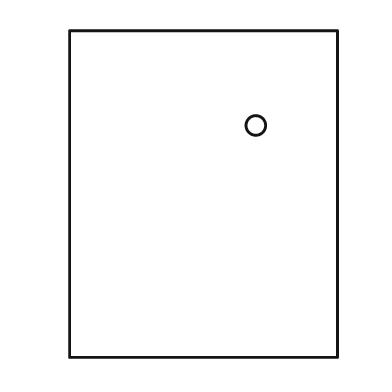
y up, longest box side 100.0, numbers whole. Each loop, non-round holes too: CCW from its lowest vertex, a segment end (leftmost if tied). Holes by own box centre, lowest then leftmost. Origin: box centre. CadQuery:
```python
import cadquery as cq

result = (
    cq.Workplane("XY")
    .moveTo(-41.0, -50.0)
    .lineTo(41.0, -50.0)
    .lineTo(41.0, 50.0)
    .lineTo(-41.0, 50.0)
    .close()
    .moveTo(16.0, 21.0)
    .circle(3.0)
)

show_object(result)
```